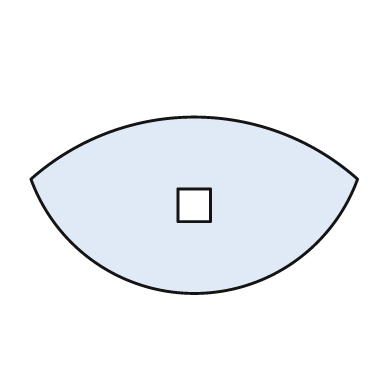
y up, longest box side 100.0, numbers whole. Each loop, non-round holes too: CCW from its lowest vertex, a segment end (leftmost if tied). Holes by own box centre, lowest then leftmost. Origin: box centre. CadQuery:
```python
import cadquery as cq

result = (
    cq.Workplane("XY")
    .moveTo(-50.0, 8.0)
    .threePointArc((0.0, -27.0), (50.0, 8.0))
    .threePointArc((0.0, 27.0), (-50.0, 8.0))
    .close()
    .moveTo(-5.0, -5.0)
    .lineTo(5.0, -5.0)
    .lineTo(5.0, 5.0)
    .lineTo(-5.0, 5.0)
    .close()
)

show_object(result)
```